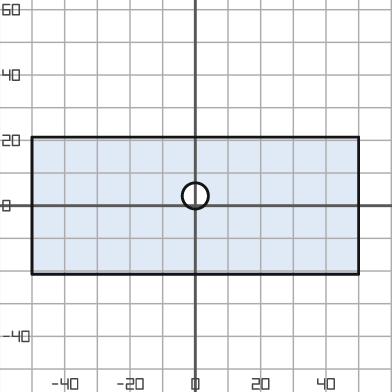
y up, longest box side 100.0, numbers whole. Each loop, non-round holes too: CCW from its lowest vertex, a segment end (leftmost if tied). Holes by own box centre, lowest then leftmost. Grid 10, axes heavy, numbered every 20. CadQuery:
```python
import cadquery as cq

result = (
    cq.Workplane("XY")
    .moveTo(-50.0, -21.0)
    .lineTo(50.0, -21.0)
    .lineTo(50.0, 21.0)
    .lineTo(-50.0, 21.0)
    .close()
    .moveTo(0.0, 3.0)
    .circle(4.0)
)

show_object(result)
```